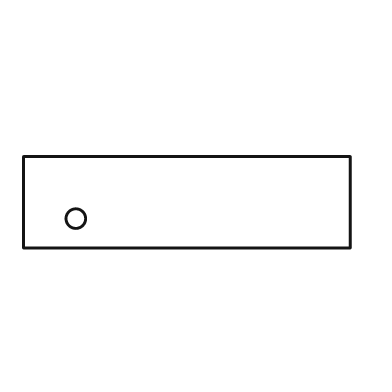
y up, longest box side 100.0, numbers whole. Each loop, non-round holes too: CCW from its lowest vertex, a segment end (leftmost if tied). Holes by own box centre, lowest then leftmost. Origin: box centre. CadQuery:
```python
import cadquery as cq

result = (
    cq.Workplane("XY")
    .moveTo(-50.0, -14.0)
    .lineTo(50.0, -14.0)
    .lineTo(50.0, 14.0)
    .lineTo(-50.0, 14.0)
    .close()
    .moveTo(-34.0, -5.0)
    .circle(3.0)
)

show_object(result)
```